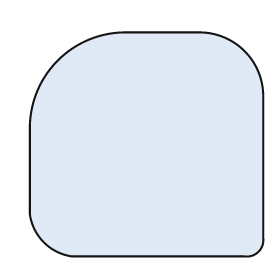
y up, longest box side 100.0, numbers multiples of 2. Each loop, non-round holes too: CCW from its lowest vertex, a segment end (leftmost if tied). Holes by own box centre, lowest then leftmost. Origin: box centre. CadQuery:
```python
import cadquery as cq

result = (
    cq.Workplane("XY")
    .moveTo(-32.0, -48.0)
    .lineTo(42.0, -48.0)
    .threePointArc((48.0, -46.0), (50.0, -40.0))
    .lineTo(50.0, 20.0)
    .threePointArc((42.0, 40.0), (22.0, 48.0))
    .lineTo(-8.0, 48.0)
    .threePointArc((-38.0, 36.0), (-50.0, 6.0))
    .lineTo(-50.0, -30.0)
    .threePointArc((-44.0, -42.0), (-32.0, -48.0))
    .close()
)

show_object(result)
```